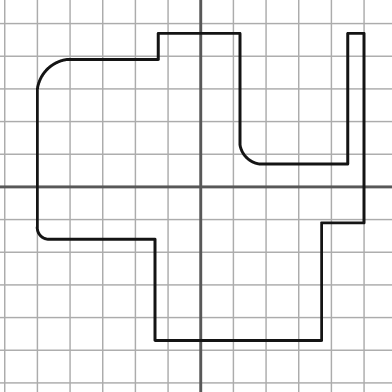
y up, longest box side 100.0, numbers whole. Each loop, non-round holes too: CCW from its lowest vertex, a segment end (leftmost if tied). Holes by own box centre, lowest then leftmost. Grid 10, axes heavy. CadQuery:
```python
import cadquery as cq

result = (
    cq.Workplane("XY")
    .moveTo(-14.0, -47.0)
    .lineTo(37.0, -47.0)
    .lineTo(37.0, -11.0)
    .lineTo(50.0, -11.0)
    .lineTo(50.0, 47.0)
    .lineTo(45.0, 47.0)
    .lineTo(45.0, 7.0)
    .lineTo(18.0, 7.0)
    .threePointArc((14.0, 9.0), (12.0, 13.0))
    .lineTo(12.0, 47.0)
    .lineTo(-13.0, 47.0)
    .lineTo(-13.0, 39.0)
    .lineTo(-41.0, 39.0)
    .threePointArc((-47.0, 36.0), (-50.0, 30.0))
    .lineTo(-50.0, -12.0)
    .threePointArc((-49.0, -15.0), (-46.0, -16.0))
    .lineTo(-14.0, -16.0)
    .close()
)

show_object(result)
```